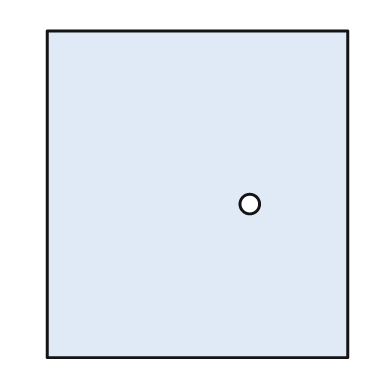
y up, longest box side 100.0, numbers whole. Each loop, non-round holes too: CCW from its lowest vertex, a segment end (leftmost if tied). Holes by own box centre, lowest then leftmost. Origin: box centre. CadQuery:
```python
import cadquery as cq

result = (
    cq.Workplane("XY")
    .moveTo(-46.0, -50.0)
    .lineTo(46.0, -50.0)
    .lineTo(46.0, 50.0)
    .lineTo(-46.0, 50.0)
    .close()
    .moveTo(16.0, -3.0)
    .circle(3.0)
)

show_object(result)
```